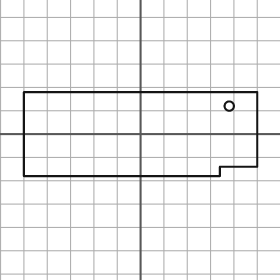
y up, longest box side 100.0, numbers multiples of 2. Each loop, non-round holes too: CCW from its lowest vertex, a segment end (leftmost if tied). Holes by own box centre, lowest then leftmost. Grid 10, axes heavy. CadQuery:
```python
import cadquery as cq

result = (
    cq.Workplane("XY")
    .moveTo(-50.0, -18.0)
    .lineTo(34.0, -18.0)
    .lineTo(34.0, -14.0)
    .lineTo(50.0, -14.0)
    .lineTo(50.0, 18.0)
    .lineTo(-50.0, 18.0)
    .close()
    .moveTo(38.0, 12.0)
    .circle(2.0)
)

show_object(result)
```